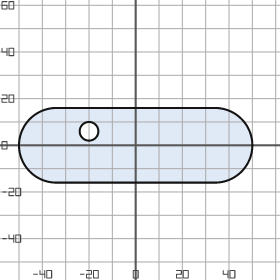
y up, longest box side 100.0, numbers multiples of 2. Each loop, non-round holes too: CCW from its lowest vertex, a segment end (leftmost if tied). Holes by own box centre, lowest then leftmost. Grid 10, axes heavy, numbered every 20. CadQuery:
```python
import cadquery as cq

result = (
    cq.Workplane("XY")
    .moveTo(-34.0, -16.0)
    .lineTo(34.0, -16.0)
    .threePointArc((50.0, 0.0), (34.0, 16.0))
    .lineTo(-34.0, 16.0)
    .threePointArc((-50.0, 0.0), (-34.0, -16.0))
    .close()
    .moveTo(-20.0, 6.0)
    .circle(4.0)
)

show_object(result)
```